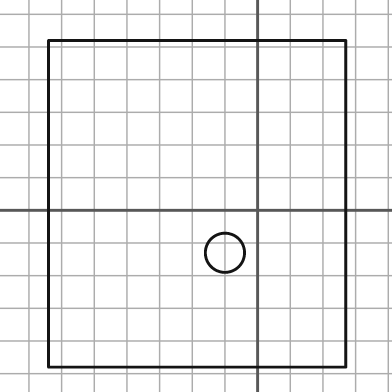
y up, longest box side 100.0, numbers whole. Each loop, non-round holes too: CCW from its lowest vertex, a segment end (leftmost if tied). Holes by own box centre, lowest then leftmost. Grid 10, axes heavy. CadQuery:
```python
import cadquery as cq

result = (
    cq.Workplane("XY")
    .moveTo(-64.0, -48.0)
    .lineTo(27.0, -48.0)
    .lineTo(27.0, 52.0)
    .lineTo(-64.0, 52.0)
    .close()
    .moveTo(-10.0, -13.0)
    .circle(6.0)
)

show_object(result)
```